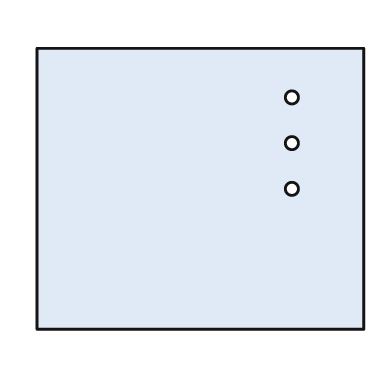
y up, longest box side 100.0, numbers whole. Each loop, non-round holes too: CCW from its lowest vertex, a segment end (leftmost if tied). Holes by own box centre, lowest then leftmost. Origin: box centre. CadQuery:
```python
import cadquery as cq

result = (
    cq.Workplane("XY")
    .moveTo(-50.0, -43.0)
    .lineTo(50.0, -43.0)
    .lineTo(50.0, 43.0)
    .lineTo(-50.0, 43.0)
    .close()
    .moveTo(28.0, 0.0)
    .circle(2.0)
    .moveTo(28.0, 14.0)
    .circle(2.0)
    .moveTo(28.0, 28.0)
    .circle(2.0)
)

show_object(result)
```